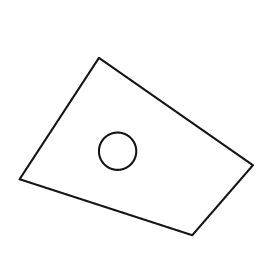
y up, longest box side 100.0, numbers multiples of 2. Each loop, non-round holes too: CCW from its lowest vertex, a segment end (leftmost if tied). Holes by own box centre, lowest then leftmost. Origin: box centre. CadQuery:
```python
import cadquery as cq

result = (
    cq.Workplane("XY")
    .moveTo(24.0, -38.0)
    .lineTo(50.0, -8.0)
    .lineTo(-16.0, 38.0)
    .lineTo(-50.0, -14.0)
    .close()
    .moveTo(-8.0, -2.0)
    .circle(8.0)
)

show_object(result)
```